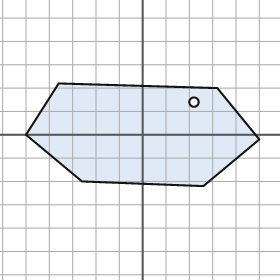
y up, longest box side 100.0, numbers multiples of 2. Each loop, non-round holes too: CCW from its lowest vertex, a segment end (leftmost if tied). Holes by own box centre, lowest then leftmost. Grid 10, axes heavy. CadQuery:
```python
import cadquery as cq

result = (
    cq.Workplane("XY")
    .moveTo(26.0, -22.0)
    .lineTo(50.0, -2.0)
    .lineTo(32.0, 20.0)
    .lineTo(-36.0, 22.0)
    .lineTo(-50.0, 0.0)
    .lineTo(-26.0, -20.0)
    .close()
    .moveTo(22.0, 14.0)
    .circle(2.0)
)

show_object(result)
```